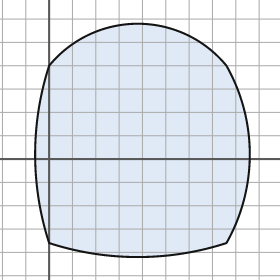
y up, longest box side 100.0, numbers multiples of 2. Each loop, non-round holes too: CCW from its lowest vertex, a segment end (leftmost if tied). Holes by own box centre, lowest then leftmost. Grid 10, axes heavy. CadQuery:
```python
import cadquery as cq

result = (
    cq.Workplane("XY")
    .moveTo(0.0, -36.0)
    .threePointArc((38.0, -42.0), (76.0, -36.0))
    .threePointArc((86.0, 2.0), (76.0, 40.0))
    .threePointArc((38.0, 58.0), (0.0, 40.0))
    .threePointArc((-6.0, 2.0), (0.0, -36.0))
    .close()
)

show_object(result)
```